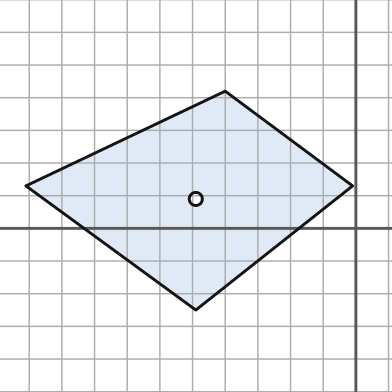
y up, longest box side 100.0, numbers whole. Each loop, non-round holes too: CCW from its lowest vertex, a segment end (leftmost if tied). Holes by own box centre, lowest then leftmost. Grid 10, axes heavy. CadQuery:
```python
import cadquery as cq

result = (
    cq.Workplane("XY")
    .moveTo(-49.0, -25.0)
    .lineTo(-1.0, 13.0)
    .lineTo(-40.0, 42.0)
    .lineTo(-101.0, 13.0)
    .close()
    .moveTo(-49.0, 9.0)
    .circle(2.0)
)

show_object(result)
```